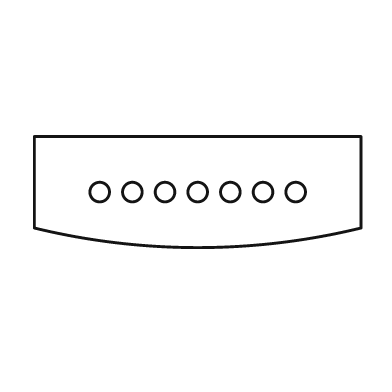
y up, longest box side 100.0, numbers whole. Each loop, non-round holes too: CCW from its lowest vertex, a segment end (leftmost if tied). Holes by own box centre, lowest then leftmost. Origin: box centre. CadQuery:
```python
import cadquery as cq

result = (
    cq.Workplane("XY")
    .moveTo(-50.0, -11.0)
    .threePointArc((0.0, -17.0), (50.0, -11.0))
    .lineTo(50.0, 17.0)
    .lineTo(-50.0, 17.0)
    .close()
    .moveTo(-30.0, 0.0)
    .circle(3.0)
    .moveTo(-20.0, 0.0)
    .circle(3.0)
    .moveTo(-10.0, 0.0)
    .circle(3.0)
    .moveTo(0.0, 0.0)
    .circle(3.0)
    .moveTo(10.0, 0.0)
    .circle(3.0)
    .moveTo(20.0, 0.0)
    .circle(3.0)
    .moveTo(30.0, 0.0)
    .circle(3.0)
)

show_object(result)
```